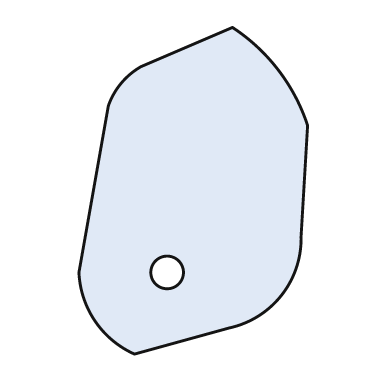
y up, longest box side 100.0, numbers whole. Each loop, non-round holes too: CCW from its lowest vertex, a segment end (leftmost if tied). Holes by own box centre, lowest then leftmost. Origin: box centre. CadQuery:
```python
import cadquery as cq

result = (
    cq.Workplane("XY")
    .moveTo(-18.0, -50.0)
    .lineTo(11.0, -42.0)
    .threePointArc((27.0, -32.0), (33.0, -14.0))
    .lineTo(35.0, 20.0)
    .threePointArc((26.0, 37.0), (12.0, 50.0))
    .lineTo(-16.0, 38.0)
    .threePointArc((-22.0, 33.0), (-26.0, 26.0))
    .lineTo(-35.0, -25.0)
    .threePointArc((-30.0, -40.0), (-18.0, -50.0))
    .close()
    .moveTo(-8.0, -25.0)
    .circle(5.0)
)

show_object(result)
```